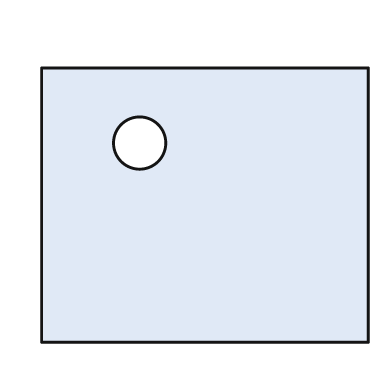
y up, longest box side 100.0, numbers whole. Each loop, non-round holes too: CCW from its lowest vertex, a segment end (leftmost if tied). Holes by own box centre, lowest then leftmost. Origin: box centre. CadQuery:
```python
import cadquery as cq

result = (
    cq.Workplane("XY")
    .moveTo(-50.0, -42.0)
    .lineTo(50.0, -42.0)
    .lineTo(50.0, 42.0)
    .lineTo(-50.0, 42.0)
    .close()
    .moveTo(-20.0, 19.0)
    .circle(8.0)
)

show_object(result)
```